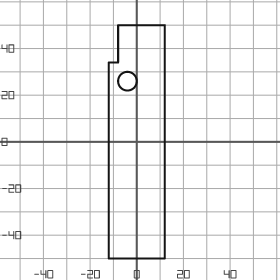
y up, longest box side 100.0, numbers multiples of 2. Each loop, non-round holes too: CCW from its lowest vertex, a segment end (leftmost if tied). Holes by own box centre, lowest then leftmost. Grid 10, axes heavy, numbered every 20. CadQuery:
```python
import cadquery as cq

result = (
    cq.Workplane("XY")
    .moveTo(-12.0, -50.0)
    .lineTo(12.0, -50.0)
    .lineTo(12.0, 50.0)
    .lineTo(-8.0, 50.0)
    .lineTo(-8.0, 34.0)
    .lineTo(-12.0, 34.0)
    .close()
    .moveTo(-4.0, 26.0)
    .circle(4.0)
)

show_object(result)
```